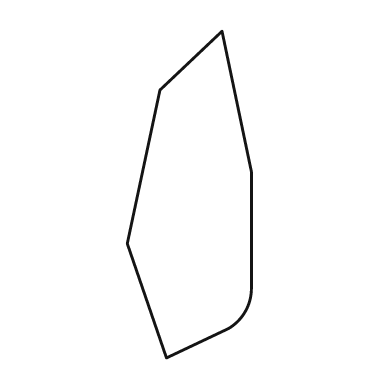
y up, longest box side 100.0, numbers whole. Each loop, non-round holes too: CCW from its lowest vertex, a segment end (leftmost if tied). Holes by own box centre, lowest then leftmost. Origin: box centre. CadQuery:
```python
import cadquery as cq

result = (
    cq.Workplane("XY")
    .moveTo(-7.0, -50.0)
    .lineTo(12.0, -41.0)
    .threePointArc((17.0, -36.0), (19.0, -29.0))
    .lineTo(19.0, 7.0)
    .lineTo(10.0, 50.0)
    .lineTo(-9.0, 32.0)
    .lineTo(-19.0, -15.0)
    .close()
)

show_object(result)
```